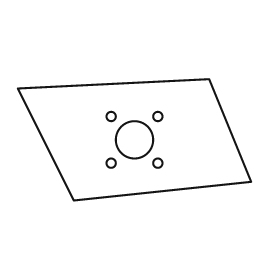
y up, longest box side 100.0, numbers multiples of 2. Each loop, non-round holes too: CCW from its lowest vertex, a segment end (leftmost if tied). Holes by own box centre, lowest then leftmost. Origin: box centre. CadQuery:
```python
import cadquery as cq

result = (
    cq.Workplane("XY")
    .moveTo(-26.0, -26.0)
    .lineTo(50.0, -18.0)
    .lineTo(32.0, 26.0)
    .lineTo(-50.0, 22.0)
    .close()
    .moveTo(-10.0, -10.0)
    .circle(2.0)
    .moveTo(10.0, -10.0)
    .circle(2.0)
    .moveTo(0.0, 0.0)
    .circle(8.0)
    .moveTo(-10.0, 10.0)
    .circle(2.0)
    .moveTo(10.0, 10.0)
    .circle(2.0)
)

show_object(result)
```